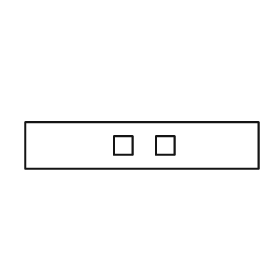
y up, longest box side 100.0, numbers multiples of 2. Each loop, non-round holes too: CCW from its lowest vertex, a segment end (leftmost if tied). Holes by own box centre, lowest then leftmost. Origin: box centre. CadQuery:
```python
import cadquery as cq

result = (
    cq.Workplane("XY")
    .moveTo(-50.0, -10.0)
    .lineTo(50.0, -10.0)
    .lineTo(50.0, 10.0)
    .lineTo(-50.0, 10.0)
    .close()
    .moveTo(-12.0, -4.0)
    .lineTo(-4.0, -4.0)
    .lineTo(-4.0, 4.0)
    .lineTo(-12.0, 4.0)
    .close()
    .moveTo(6.0, -4.0)
    .lineTo(14.0, -4.0)
    .lineTo(14.0, 4.0)
    .lineTo(6.0, 4.0)
    .close()
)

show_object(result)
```